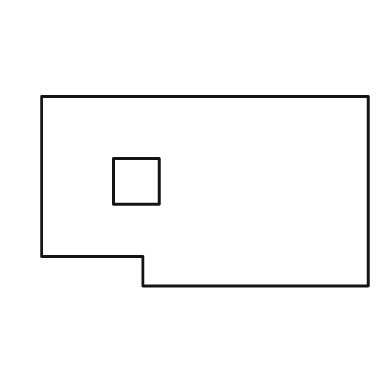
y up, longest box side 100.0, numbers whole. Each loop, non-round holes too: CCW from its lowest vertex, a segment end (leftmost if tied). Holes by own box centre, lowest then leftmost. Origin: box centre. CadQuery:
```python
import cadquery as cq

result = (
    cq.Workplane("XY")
    .moveTo(-19.0, -29.0)
    .lineTo(50.0, -29.0)
    .lineTo(50.0, 29.0)
    .lineTo(-50.0, 29.0)
    .lineTo(-50.0, -20.0)
    .lineTo(-19.0, -20.0)
    .close()
    .moveTo(-28.0, -4.0)
    .lineTo(-14.0, -4.0)
    .lineTo(-14.0, 10.0)
    .lineTo(-28.0, 10.0)
    .close()
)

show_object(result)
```